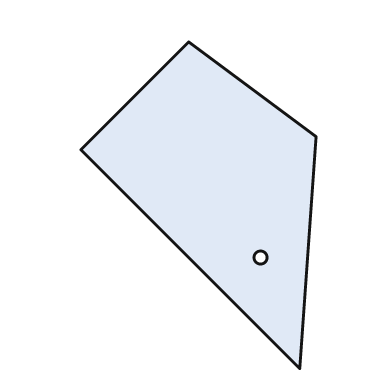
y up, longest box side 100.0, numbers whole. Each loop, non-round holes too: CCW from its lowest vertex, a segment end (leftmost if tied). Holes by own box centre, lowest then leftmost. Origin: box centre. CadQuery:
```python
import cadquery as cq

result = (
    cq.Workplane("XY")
    .moveTo(31.0, -50.0)
    .lineTo(36.0, 21.0)
    .lineTo(-3.0, 50.0)
    .lineTo(-36.0, 17.0)
    .close()
    .moveTo(19.0, -16.0)
    .circle(2.0)
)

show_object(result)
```